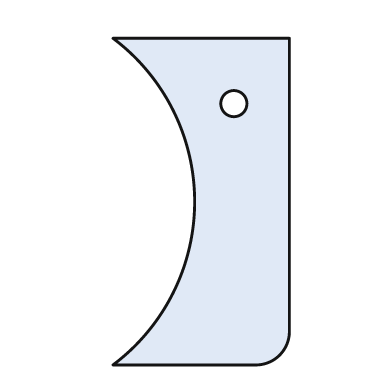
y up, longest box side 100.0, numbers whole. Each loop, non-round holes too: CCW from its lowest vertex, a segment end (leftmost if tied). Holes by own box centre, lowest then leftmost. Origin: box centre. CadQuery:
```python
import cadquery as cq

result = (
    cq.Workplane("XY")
    .moveTo(-27.0, -50.0)
    .lineTo(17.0, -50.0)
    .threePointArc((24.0, -47.0), (27.0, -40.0))
    .lineTo(27.0, 50.0)
    .lineTo(-27.0, 50.0)
    .threePointArc((-2.0, 0.0), (-27.0, -50.0))
    .close()
    .moveTo(10.0, 30.0)
    .circle(4.0)
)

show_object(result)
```